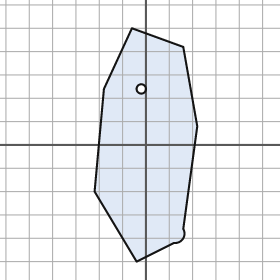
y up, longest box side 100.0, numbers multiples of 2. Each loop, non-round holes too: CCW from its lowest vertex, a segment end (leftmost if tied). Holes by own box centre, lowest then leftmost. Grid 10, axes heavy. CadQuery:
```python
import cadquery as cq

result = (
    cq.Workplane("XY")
    .moveTo(-4.0, -50.0)
    .lineTo(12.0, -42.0)
    .threePointArc((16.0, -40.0), (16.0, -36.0))
    .lineTo(22.0, 8.0)
    .lineTo(16.0, 42.0)
    .lineTo(-6.0, 50.0)
    .lineTo(-18.0, 24.0)
    .lineTo(-22.0, -20.0)
    .close()
    .moveTo(-2.0, 24.0)
    .circle(2.0)
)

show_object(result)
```